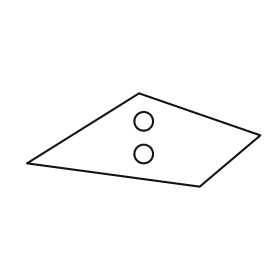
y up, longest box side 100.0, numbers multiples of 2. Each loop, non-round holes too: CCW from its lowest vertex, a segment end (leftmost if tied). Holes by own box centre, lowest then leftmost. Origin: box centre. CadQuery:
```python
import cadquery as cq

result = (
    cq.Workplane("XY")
    .moveTo(24.0, -20.0)
    .lineTo(50.0, 2.0)
    .lineTo(-2.0, 20.0)
    .lineTo(-50.0, -10.0)
    .close()
    .moveTo(0.0, -6.0)
    .circle(4.0)
    .moveTo(0.0, 8.0)
    .circle(4.0)
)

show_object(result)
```